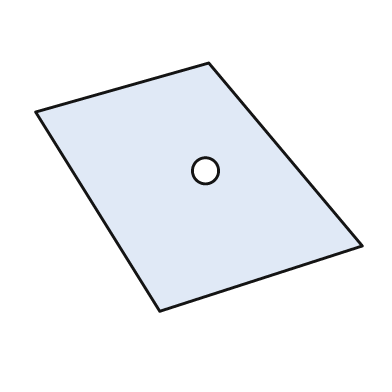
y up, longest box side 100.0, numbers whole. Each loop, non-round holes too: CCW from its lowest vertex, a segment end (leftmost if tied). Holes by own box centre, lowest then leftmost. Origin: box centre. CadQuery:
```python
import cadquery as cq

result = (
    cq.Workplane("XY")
    .moveTo(-12.0, -38.0)
    .lineTo(50.0, -18.0)
    .lineTo(3.0, 38.0)
    .lineTo(-50.0, 23.0)
    .close()
    .moveTo(2.0, 5.0)
    .circle(4.0)
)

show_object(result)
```